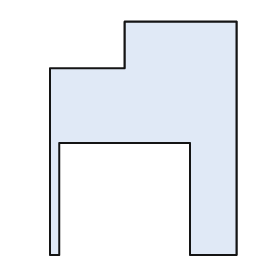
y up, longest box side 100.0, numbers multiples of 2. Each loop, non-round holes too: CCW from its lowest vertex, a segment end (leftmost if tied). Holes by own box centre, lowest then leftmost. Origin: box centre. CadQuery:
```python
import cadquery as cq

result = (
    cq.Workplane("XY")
    .moveTo(-40.0, -50.0)
    .lineTo(-36.0, -50.0)
    .lineTo(-36.0, -2.0)
    .lineTo(20.0, -2.0)
    .lineTo(20.0, -50.0)
    .lineTo(40.0, -50.0)
    .lineTo(40.0, 50.0)
    .lineTo(-8.0, 50.0)
    .lineTo(-8.0, 30.0)
    .lineTo(-40.0, 30.0)
    .close()
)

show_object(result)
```